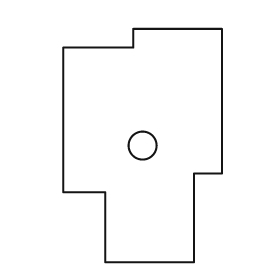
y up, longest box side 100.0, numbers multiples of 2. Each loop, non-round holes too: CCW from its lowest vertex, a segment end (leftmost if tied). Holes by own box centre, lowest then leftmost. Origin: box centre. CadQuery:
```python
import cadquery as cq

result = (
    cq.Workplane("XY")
    .moveTo(-16.0, -50.0)
    .lineTo(22.0, -50.0)
    .lineTo(22.0, -12.0)
    .lineTo(34.0, -12.0)
    .lineTo(34.0, 50.0)
    .lineTo(-4.0, 50.0)
    .lineTo(-4.0, 42.0)
    .lineTo(-34.0, 42.0)
    .lineTo(-34.0, -20.0)
    .lineTo(-16.0, -20.0)
    .close()
    .moveTo(0.0, 0.0)
    .circle(6.0)
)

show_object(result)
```